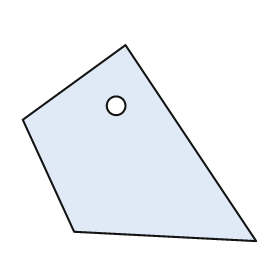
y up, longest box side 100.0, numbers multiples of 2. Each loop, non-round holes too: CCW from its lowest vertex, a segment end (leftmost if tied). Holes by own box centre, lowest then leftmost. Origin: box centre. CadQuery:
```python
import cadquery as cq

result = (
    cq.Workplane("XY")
    .moveTo(50.0, -42.0)
    .lineTo(-6.0, 42.0)
    .lineTo(-50.0, 10.0)
    .lineTo(-28.0, -38.0)
    .close()
    .moveTo(-10.0, 16.0)
    .circle(4.0)
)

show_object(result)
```